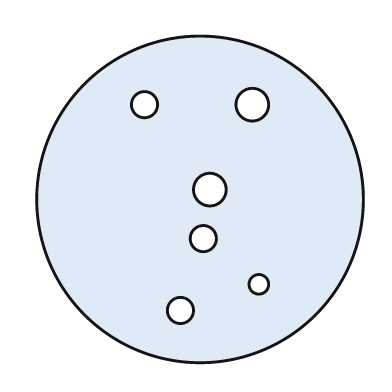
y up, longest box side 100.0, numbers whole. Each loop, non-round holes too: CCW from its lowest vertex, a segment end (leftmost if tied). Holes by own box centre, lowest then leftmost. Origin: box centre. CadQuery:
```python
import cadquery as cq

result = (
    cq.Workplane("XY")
    .moveTo(0.0, 0.0)
    .circle(50.0)
    .moveTo(-6.0, -34.0)
    .circle(4.0)
    .moveTo(18.0, -26.0)
    .circle(3.0)
    .moveTo(1.0, -12.0)
    .circle(4.0)
    .moveTo(3.0, 3.0)
    .circle(5.0)
    .moveTo(-17.0, 29.0)
    .circle(4.0)
    .moveTo(16.0, 29.0)
    .circle(5.0)
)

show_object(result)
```